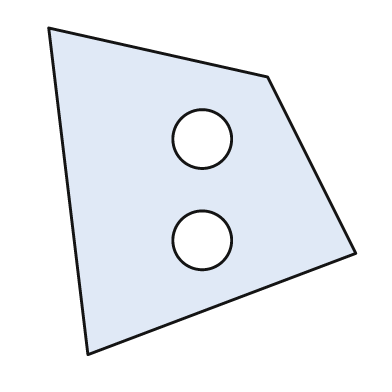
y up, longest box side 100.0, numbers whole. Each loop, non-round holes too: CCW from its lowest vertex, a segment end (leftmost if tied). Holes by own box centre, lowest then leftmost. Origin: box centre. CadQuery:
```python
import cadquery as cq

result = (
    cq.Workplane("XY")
    .moveTo(-35.0, -50.0)
    .lineTo(47.0, -19.0)
    .lineTo(20.0, 35.0)
    .lineTo(-47.0, 50.0)
    .close()
    .moveTo(0.0, -15.0)
    .circle(9.0)
    .moveTo(0.0, 16.0)
    .circle(9.0)
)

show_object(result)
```